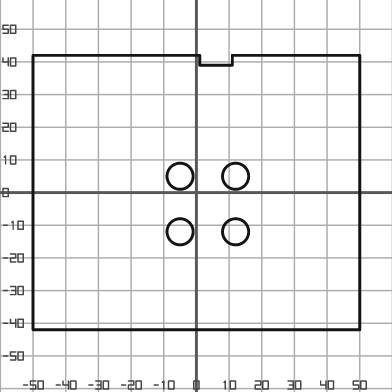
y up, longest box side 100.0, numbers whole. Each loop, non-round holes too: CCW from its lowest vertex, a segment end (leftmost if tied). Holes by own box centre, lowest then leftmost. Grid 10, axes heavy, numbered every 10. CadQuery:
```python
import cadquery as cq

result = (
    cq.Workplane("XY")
    .moveTo(-50.0, -42.0)
    .lineTo(50.0, -42.0)
    .lineTo(50.0, 42.0)
    .lineTo(11.0, 42.0)
    .lineTo(11.0, 39.0)
    .lineTo(1.0, 39.0)
    .lineTo(1.0, 42.0)
    .lineTo(-50.0, 42.0)
    .close()
    .moveTo(-5.0, -12.0)
    .circle(4.0)
    .moveTo(12.0, -12.0)
    .circle(4.0)
    .moveTo(-5.0, 5.0)
    .circle(4.0)
    .moveTo(12.0, 5.0)
    .circle(4.0)
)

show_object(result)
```